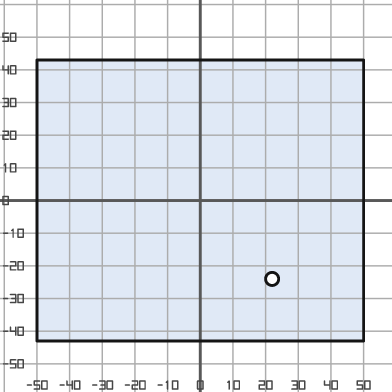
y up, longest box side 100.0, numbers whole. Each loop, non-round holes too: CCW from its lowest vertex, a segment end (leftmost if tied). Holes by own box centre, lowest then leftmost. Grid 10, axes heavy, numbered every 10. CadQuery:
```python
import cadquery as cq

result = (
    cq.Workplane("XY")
    .moveTo(-50.0, -43.0)
    .lineTo(50.0, -43.0)
    .lineTo(50.0, 43.0)
    .lineTo(-50.0, 43.0)
    .close()
    .moveTo(22.0, -24.0)
    .circle(2.0)
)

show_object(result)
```